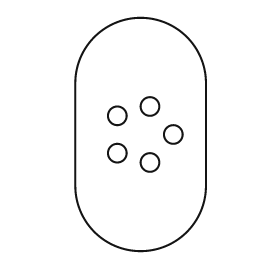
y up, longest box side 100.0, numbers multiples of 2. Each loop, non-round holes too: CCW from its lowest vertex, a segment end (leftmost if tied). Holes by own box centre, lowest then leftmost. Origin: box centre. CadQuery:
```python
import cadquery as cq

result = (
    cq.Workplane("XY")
    .moveTo(-28.0, -22.0)
    .threePointArc((0.0, -50.0), (28.0, -22.0))
    .lineTo(28.0, 22.0)
    .threePointArc((0.0, 50.0), (-28.0, 22.0))
    .close()
    .moveTo(4.0, -12.0)
    .circle(4.0)
    .moveTo(-10.0, -8.0)
    .circle(4.0)
    .moveTo(14.0, 0.0)
    .circle(4.0)
    .moveTo(-10.0, 8.0)
    .circle(4.0)
    .moveTo(4.0, 12.0)
    .circle(4.0)
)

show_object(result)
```